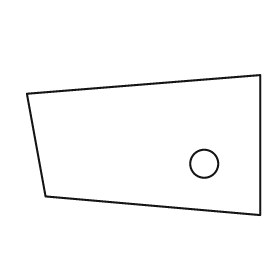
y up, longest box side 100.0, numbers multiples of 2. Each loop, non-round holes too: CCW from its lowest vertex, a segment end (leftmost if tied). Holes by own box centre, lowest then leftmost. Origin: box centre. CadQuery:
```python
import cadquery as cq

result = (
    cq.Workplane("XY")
    .moveTo(50.0, -30.0)
    .lineTo(50.0, 30.0)
    .lineTo(-50.0, 22.0)
    .lineTo(-42.0, -22.0)
    .close()
    .moveTo(26.0, -8.0)
    .circle(6.0)
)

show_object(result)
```